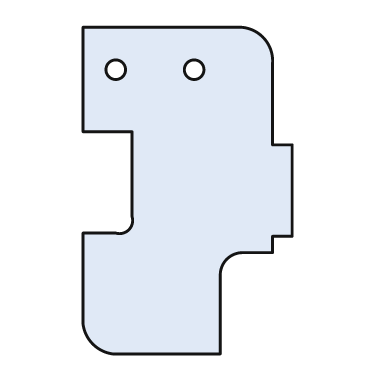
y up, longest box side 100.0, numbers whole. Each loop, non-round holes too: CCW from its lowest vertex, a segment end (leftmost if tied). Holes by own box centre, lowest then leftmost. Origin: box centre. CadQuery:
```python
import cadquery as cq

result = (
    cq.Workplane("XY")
    .moveTo(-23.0, -50.0)
    .lineTo(10.0, -50.0)
    .lineTo(10.0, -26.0)
    .threePointArc((12.0, -21.0), (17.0, -19.0))
    .lineTo(26.0, -19.0)
    .lineTo(26.0, -14.0)
    .lineTo(32.0, -14.0)
    .lineTo(32.0, 14.0)
    .lineTo(26.0, 14.0)
    .lineTo(26.0, 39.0)
    .threePointArc((23.0, 47.0), (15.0, 50.0))
    .lineTo(-32.0, 50.0)
    .lineTo(-32.0, 18.0)
    .lineTo(-17.0, 18.0)
    .lineTo(-17.0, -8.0)
    .threePointArc((-18.0, -12.0), (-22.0, -13.0))
    .lineTo(-32.0, -13.0)
    .lineTo(-32.0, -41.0)
    .threePointArc((-29.0, -47.0), (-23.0, -50.0))
    .close()
    .moveTo(-22.0, 37.0)
    .circle(3.0)
    .moveTo(2.0, 37.0)
    .circle(3.0)
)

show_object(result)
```